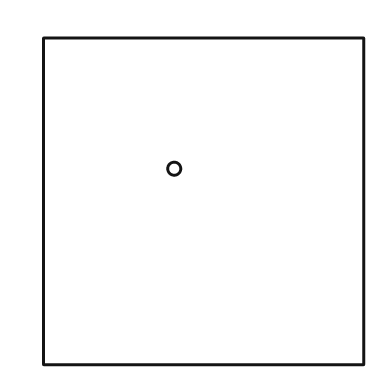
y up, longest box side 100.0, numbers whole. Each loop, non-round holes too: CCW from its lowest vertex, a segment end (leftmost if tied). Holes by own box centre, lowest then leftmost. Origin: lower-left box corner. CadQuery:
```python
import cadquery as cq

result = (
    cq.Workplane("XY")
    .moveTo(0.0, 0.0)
    .lineTo(98.0, 0.0)
    .lineTo(98.0, 100.0)
    .lineTo(0.0, 100.0)
    .close()
    .moveTo(40.0, 60.0)
    .circle(2.0)
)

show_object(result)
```